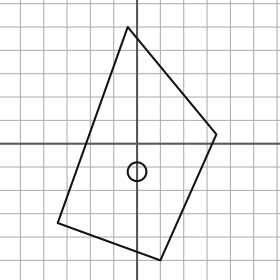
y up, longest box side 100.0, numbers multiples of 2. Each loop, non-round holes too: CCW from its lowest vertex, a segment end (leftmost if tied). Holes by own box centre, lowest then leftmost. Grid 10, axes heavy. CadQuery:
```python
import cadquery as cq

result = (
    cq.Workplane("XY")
    .moveTo(10.0, -50.0)
    .lineTo(34.0, 4.0)
    .lineTo(-4.0, 50.0)
    .lineTo(-34.0, -34.0)
    .close()
    .moveTo(0.0, -12.0)
    .circle(4.0)
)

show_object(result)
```